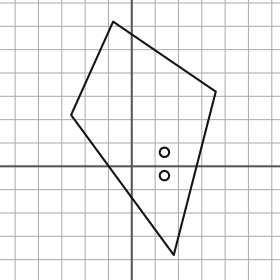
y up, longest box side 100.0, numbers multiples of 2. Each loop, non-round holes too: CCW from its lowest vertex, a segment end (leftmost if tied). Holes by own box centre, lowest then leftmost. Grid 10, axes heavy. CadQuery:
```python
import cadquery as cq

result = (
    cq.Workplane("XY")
    .moveTo(18.0, -38.0)
    .lineTo(36.0, 32.0)
    .lineTo(-8.0, 62.0)
    .lineTo(-26.0, 22.0)
    .close()
    .moveTo(14.0, -4.0)
    .circle(2.0)
    .moveTo(14.0, 6.0)
    .circle(2.0)
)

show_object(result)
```